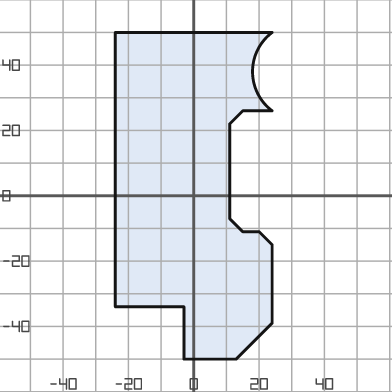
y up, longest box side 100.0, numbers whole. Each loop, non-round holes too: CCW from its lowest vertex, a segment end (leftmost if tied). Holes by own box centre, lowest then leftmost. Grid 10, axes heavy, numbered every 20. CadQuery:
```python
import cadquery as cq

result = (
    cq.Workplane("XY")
    .moveTo(-3.0, -50.0)
    .lineTo(13.0, -50.0)
    .lineTo(24.0, -39.0)
    .lineTo(24.0, -15.0)
    .lineTo(20.0, -11.0)
    .lineTo(15.0, -11.0)
    .lineTo(11.0, -7.0)
    .lineTo(11.0, 22.0)
    .lineTo(15.0, 26.0)
    .lineTo(24.0, 26.0)
    .threePointArc((18.0, 38.0), (24.0, 50.0))
    .lineTo(-24.0, 50.0)
    .lineTo(-24.0, -34.0)
    .lineTo(-3.0, -34.0)
    .close()
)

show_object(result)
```